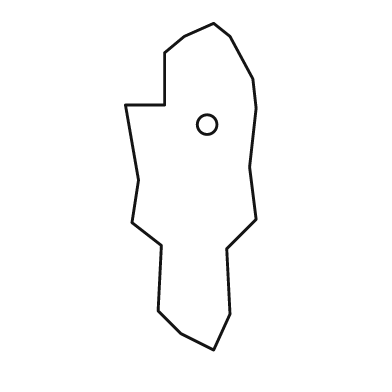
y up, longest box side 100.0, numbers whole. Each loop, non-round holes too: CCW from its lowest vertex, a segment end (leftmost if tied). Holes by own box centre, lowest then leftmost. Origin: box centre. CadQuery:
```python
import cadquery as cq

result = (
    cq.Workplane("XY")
    .moveTo(7.0, -50.0)
    .lineTo(12.0, -39.0)
    .lineTo(11.0, -19.0)
    .lineTo(20.0, -10.0)
    .lineTo(18.0, 6.0)
    .lineTo(20.0, 24.0)
    .lineTo(19.0, 33.0)
    .lineTo(12.0, 46.0)
    .lineTo(7.0, 50.0)
    .lineTo(-2.0, 46.0)
    .lineTo(-8.0, 41.0)
    .lineTo(-8.0, 25.0)
    .lineTo(-20.0, 25.0)
    .lineTo(-16.0, 2.0)
    .lineTo(-18.0, -11.0)
    .lineTo(-9.0, -18.0)
    .lineTo(-10.0, -38.0)
    .lineTo(-3.0, -45.0)
    .close()
    .moveTo(5.0, 19.0)
    .circle(3.0)
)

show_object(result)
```